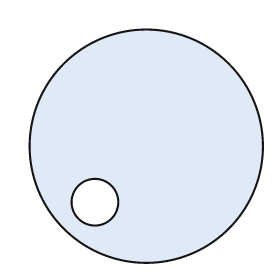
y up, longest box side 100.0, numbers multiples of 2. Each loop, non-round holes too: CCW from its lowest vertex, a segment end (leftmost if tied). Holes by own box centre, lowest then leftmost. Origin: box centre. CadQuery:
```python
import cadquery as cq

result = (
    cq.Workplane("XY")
    .moveTo(0.0, 0.0)
    .circle(50.0)
    .moveTo(-22.0, -24.0)
    .circle(10.0)
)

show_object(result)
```